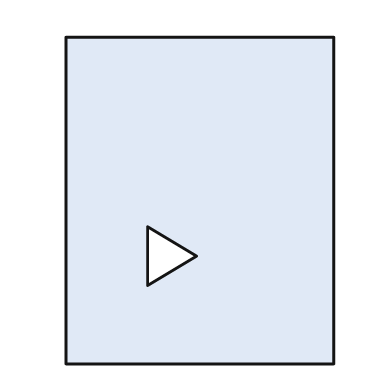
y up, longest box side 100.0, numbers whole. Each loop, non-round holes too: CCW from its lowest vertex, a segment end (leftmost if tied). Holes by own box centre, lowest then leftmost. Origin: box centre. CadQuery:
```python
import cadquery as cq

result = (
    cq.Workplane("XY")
    .moveTo(-41.0, -50.0)
    .lineTo(41.0, -50.0)
    .lineTo(41.0, 50.0)
    .lineTo(-41.0, 50.0)
    .close()
    .moveTo(-16.0, -26.0)
    .lineTo(-1.0, -17.0)
    .lineTo(-16.0, -8.0)
    .close()
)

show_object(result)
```